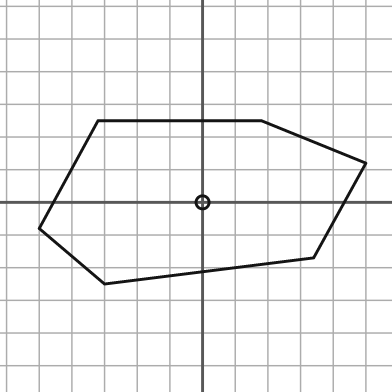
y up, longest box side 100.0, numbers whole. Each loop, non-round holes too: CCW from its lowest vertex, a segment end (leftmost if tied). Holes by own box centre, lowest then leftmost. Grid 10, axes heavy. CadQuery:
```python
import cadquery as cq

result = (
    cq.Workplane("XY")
    .moveTo(-30.0, -25.0)
    .lineTo(34.0, -17.0)
    .lineTo(50.0, 12.0)
    .lineTo(18.0, 25.0)
    .lineTo(-32.0, 25.0)
    .lineTo(-50.0, -8.0)
    .close()
    .moveTo(0.0, 0.0)
    .circle(2.0)
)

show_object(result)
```